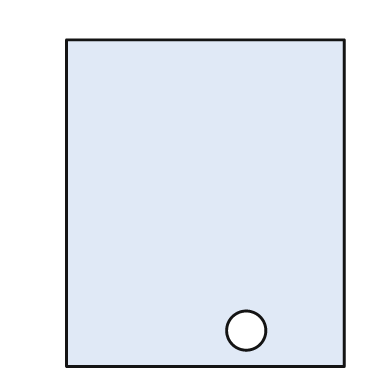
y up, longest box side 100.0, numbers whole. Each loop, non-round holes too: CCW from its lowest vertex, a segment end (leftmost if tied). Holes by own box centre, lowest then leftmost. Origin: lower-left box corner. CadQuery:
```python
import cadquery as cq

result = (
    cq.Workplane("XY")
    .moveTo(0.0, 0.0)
    .lineTo(85.0, 0.0)
    .lineTo(85.0, 100.0)
    .lineTo(0.0, 100.0)
    .close()
    .moveTo(55.0, 11.0)
    .circle(6.0)
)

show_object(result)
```